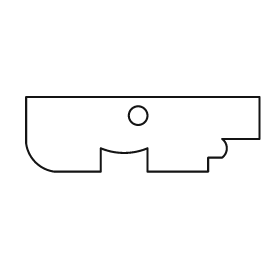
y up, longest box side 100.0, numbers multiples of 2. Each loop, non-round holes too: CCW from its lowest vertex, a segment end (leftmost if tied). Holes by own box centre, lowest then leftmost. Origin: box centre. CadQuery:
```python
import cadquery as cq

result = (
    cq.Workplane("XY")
    .moveTo(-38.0, -16.0)
    .lineTo(-18.0, -16.0)
    .lineTo(-18.0, -6.0)
    .threePointArc((-8.0, -8.0), (2.0, -6.0))
    .lineTo(2.0, -16.0)
    .lineTo(28.0, -16.0)
    .lineTo(28.0, -10.0)
    .lineTo(34.0, -10.0)
    .threePointArc((36.0, -6.0), (34.0, -2.0))
    .lineTo(50.0, -2.0)
    .lineTo(50.0, 16.0)
    .lineTo(-50.0, 16.0)
    .lineTo(-50.0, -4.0)
    .threePointArc((-46.0, -12.0), (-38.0, -16.0))
    .close()
    .moveTo(-2.0, 8.0)
    .circle(4.0)
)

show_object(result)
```